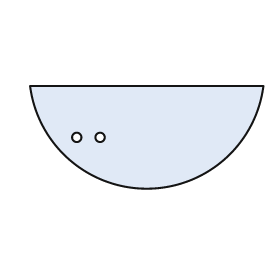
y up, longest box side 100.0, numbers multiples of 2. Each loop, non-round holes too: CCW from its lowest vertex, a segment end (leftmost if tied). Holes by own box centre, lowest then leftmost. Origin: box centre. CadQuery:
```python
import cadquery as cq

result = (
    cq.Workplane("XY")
    .moveTo(-50.0, 22.0)
    .threePointArc((0.0, -22.0), (50.0, 22.0))
    .close()
    .moveTo(-30.0, 0.0)
    .circle(2.0)
    .moveTo(-20.0, 0.0)
    .circle(2.0)
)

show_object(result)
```